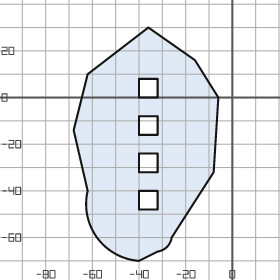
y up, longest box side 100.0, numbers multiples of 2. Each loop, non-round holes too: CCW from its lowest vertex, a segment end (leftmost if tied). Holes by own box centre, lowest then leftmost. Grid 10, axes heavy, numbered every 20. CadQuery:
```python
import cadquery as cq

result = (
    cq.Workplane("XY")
    .moveTo(-40.0, -70.0)
    .lineTo(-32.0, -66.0)
    .threePointArc((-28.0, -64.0), (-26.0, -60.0))
    .lineTo(-8.0, -32.0)
    .lineTo(-6.0, 0.0)
    .lineTo(-16.0, 16.0)
    .lineTo(-36.0, 30.0)
    .lineTo(-62.0, 10.0)
    .lineTo(-68.0, -14.0)
    .lineTo(-62.0, -40.0)
    .threePointArc((-58.0, -60.0), (-40.0, -70.0))
    .close()
    .moveTo(-40.0, -48.0)
    .lineTo(-32.0, -48.0)
    .lineTo(-32.0, -40.0)
    .lineTo(-40.0, -40.0)
    .close()
    .moveTo(-40.0, -32.0)
    .lineTo(-32.0, -32.0)
    .lineTo(-32.0, -24.0)
    .lineTo(-40.0, -24.0)
    .close()
    .moveTo(-40.0, -16.0)
    .lineTo(-32.0, -16.0)
    .lineTo(-32.0, -8.0)
    .lineTo(-40.0, -8.0)
    .close()
    .moveTo(-40.0, 0.0)
    .lineTo(-32.0, 0.0)
    .lineTo(-32.0, 8.0)
    .lineTo(-40.0, 8.0)
    .close()
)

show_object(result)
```